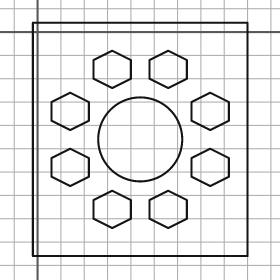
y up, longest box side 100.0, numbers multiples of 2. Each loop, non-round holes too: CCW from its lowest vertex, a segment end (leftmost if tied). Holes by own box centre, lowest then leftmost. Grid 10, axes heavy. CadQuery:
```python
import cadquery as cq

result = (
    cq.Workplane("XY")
    .moveTo(-2.0, -96.0)
    .lineTo(90.0, -96.0)
    .lineTo(90.0, 4.0)
    .lineTo(-2.0, 4.0)
    .close()
    .moveTo(32.0, -84.0)
    .lineTo(40.0, -80.0)
    .lineTo(40.0, -72.0)
    .lineTo(32.0, -68.0)
    .lineTo(24.0, -72.0)
    .lineTo(24.0, -80.0)
    .close()
    .moveTo(56.0, -84.0)
    .lineTo(64.0, -80.0)
    .lineTo(64.0, -72.0)
    .lineTo(56.0, -68.0)
    .lineTo(48.0, -72.0)
    .lineTo(48.0, -80.0)
    .close()
    .moveTo(14.0, -66.0)
    .lineTo(22.0, -62.0)
    .lineTo(22.0, -54.0)
    .lineTo(14.0, -50.0)
    .lineTo(6.0, -54.0)
    .lineTo(6.0, -62.0)
    .close()
    .moveTo(74.0, -66.0)
    .lineTo(82.0, -62.0)
    .lineTo(82.0, -54.0)
    .lineTo(74.0, -50.0)
    .lineTo(66.0, -54.0)
    .lineTo(66.0, -62.0)
    .close()
    .moveTo(44.0, -46.0)
    .circle(18.0)
    .moveTo(14.0, -42.0)
    .lineTo(22.0, -38.0)
    .lineTo(22.0, -30.0)
    .lineTo(14.0, -26.0)
    .lineTo(6.0, -30.0)
    .lineTo(6.0, -38.0)
    .close()
    .moveTo(74.0, -42.0)
    .lineTo(82.0, -38.0)
    .lineTo(82.0, -30.0)
    .lineTo(74.0, -26.0)
    .lineTo(66.0, -30.0)
    .lineTo(66.0, -38.0)
    .close()
    .moveTo(32.0, -24.0)
    .lineTo(40.0, -20.0)
    .lineTo(40.0, -12.0)
    .lineTo(32.0, -8.0)
    .lineTo(24.0, -12.0)
    .lineTo(24.0, -20.0)
    .close()
    .moveTo(56.0, -24.0)
    .lineTo(64.0, -20.0)
    .lineTo(64.0, -12.0)
    .lineTo(56.0, -8.0)
    .lineTo(48.0, -12.0)
    .lineTo(48.0, -20.0)
    .close()
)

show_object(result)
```